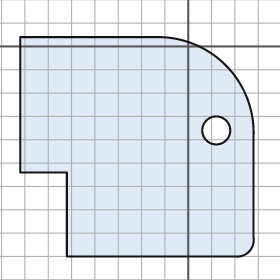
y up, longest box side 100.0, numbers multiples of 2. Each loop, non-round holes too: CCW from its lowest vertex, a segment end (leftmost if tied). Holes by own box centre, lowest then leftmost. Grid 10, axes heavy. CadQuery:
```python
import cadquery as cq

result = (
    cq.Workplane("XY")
    .moveTo(-52.0, -90.0)
    .lineTo(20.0, -90.0)
    .threePointArc((26.0, -88.0), (28.0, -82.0))
    .lineTo(28.0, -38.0)
    .threePointArc((16.0, -8.0), (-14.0, 4.0))
    .lineTo(-72.0, 4.0)
    .lineTo(-72.0, -54.0)
    .lineTo(-52.0, -54.0)
    .close()
    .moveTo(12.0, -36.0)
    .circle(6.0)
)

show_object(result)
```